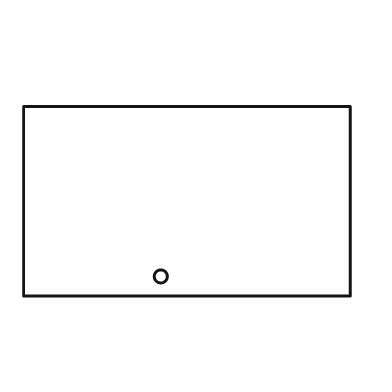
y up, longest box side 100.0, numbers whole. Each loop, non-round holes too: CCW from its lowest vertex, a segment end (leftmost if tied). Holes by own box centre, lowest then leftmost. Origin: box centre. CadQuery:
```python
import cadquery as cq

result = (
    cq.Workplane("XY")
    .moveTo(-50.0, -29.0)
    .lineTo(50.0, -29.0)
    .lineTo(50.0, 29.0)
    .lineTo(-50.0, 29.0)
    .close()
    .moveTo(-8.0, -23.0)
    .circle(2.0)
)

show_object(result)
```